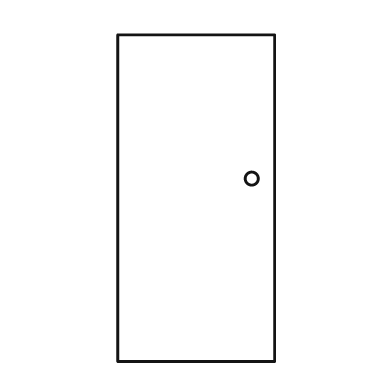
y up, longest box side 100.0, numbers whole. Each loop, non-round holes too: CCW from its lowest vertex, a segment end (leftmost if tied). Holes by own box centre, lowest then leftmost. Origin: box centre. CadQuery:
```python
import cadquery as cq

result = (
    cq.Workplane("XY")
    .moveTo(-24.0, -50.0)
    .lineTo(24.0, -50.0)
    .lineTo(24.0, 50.0)
    .lineTo(-24.0, 50.0)
    .close()
    .moveTo(17.0, 6.0)
    .circle(2.0)
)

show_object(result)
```